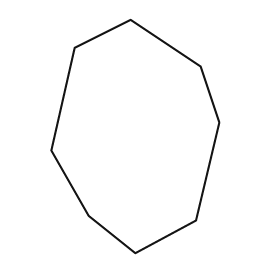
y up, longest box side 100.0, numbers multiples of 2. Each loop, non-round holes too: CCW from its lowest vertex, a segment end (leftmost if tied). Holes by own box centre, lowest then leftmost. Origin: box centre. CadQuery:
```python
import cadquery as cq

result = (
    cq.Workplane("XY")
    .moveTo(0.0, -50.0)
    .lineTo(26.0, -36.0)
    .lineTo(36.0, 6.0)
    .lineTo(28.0, 30.0)
    .lineTo(-2.0, 50.0)
    .lineTo(-26.0, 38.0)
    .lineTo(-36.0, -6.0)
    .lineTo(-20.0, -34.0)
    .close()
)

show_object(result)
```